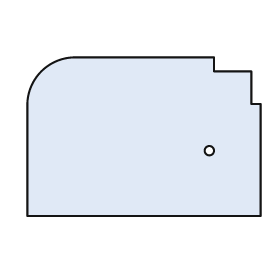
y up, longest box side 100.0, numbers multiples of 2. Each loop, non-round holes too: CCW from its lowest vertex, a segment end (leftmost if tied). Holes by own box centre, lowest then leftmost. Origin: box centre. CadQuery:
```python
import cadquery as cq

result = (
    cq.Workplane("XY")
    .moveTo(-50.0, -34.0)
    .lineTo(50.0, -34.0)
    .lineTo(50.0, 14.0)
    .lineTo(46.0, 14.0)
    .lineTo(46.0, 28.0)
    .lineTo(30.0, 28.0)
    .lineTo(30.0, 34.0)
    .lineTo(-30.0, 34.0)
    .threePointArc((-44.0, 28.0), (-50.0, 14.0))
    .close()
    .moveTo(28.0, -6.0)
    .circle(2.0)
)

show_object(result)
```